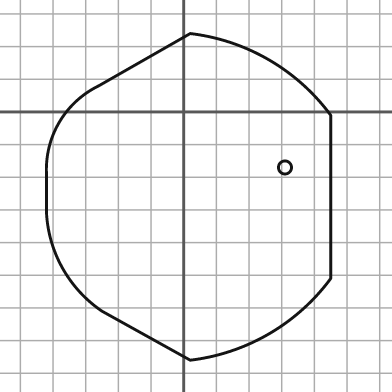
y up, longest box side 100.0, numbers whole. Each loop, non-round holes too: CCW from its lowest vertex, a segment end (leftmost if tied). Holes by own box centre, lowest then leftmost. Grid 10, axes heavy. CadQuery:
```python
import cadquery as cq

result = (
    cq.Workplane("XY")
    .moveTo(2.0, -76.0)
    .threePointArc((26.0, -68.0), (45.0, -51.0))
    .lineTo(45.0, -1.0)
    .threePointArc((26.0, 16.0), (2.0, 24.0))
    .lineTo(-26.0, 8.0)
    .threePointArc((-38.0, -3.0), (-42.0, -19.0))
    .lineTo(-42.0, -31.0)
    .threePointArc((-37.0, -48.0), (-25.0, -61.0))
    .close()
    .moveTo(31.0, -17.0)
    .circle(2.0)
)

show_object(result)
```